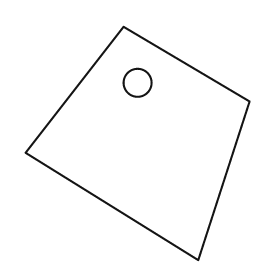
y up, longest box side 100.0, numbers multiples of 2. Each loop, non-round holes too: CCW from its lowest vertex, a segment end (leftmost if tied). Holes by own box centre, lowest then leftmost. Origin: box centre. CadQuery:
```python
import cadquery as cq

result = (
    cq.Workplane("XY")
    .moveTo(26.0, -50.0)
    .lineTo(48.0, 18.0)
    .lineTo(-6.0, 50.0)
    .lineTo(-48.0, -4.0)
    .close()
    .moveTo(0.0, 26.0)
    .circle(6.0)
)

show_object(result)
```